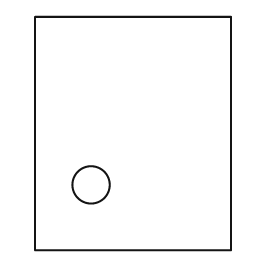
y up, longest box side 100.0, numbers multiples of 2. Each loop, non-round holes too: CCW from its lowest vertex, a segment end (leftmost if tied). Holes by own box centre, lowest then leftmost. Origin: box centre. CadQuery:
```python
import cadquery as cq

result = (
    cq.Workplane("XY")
    .moveTo(-42.0, -50.0)
    .lineTo(42.0, -50.0)
    .lineTo(42.0, 50.0)
    .lineTo(-42.0, 50.0)
    .close()
    .moveTo(-18.0, -22.0)
    .circle(8.0)
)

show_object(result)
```